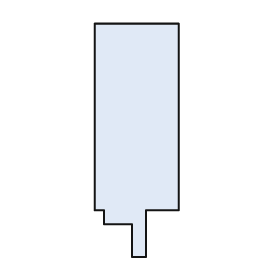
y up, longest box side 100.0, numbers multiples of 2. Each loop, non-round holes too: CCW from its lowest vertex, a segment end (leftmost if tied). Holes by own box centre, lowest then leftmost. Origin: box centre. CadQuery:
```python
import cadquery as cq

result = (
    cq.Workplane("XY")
    .moveTo(-2.0, -50.0)
    .lineTo(4.0, -50.0)
    .lineTo(4.0, -30.0)
    .lineTo(18.0, -30.0)
    .lineTo(18.0, 50.0)
    .lineTo(-18.0, 50.0)
    .lineTo(-18.0, -30.0)
    .lineTo(-14.0, -30.0)
    .lineTo(-14.0, -36.0)
    .lineTo(-2.0, -36.0)
    .close()
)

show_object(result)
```